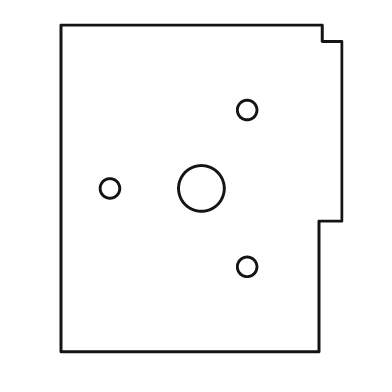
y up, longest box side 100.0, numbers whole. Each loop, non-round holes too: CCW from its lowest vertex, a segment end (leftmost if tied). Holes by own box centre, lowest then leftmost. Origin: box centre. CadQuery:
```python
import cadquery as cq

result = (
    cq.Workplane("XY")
    .moveTo(-43.0, -50.0)
    .lineTo(36.0, -50.0)
    .lineTo(36.0, -10.0)
    .lineTo(43.0, -10.0)
    .lineTo(43.0, 45.0)
    .lineTo(37.0, 45.0)
    .lineTo(37.0, 50.0)
    .lineTo(-43.0, 50.0)
    .close()
    .moveTo(14.0, -24.0)
    .circle(3.0)
    .moveTo(-28.0, 0.0)
    .circle(3.0)
    .moveTo(0.0, 0.0)
    .circle(7.0)
    .moveTo(14.0, 24.0)
    .circle(3.0)
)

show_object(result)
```